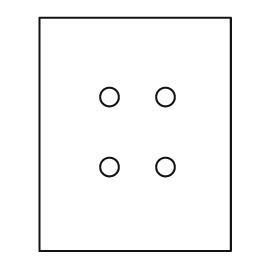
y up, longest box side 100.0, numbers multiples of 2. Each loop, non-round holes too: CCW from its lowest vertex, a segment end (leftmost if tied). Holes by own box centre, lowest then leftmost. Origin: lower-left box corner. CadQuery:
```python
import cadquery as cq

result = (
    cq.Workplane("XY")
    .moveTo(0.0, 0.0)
    .lineTo(82.0, 0.0)
    .lineTo(82.0, 100.0)
    .lineTo(0.0, 100.0)
    .close()
    .moveTo(30.0, 36.0)
    .circle(4.0)
    .moveTo(54.0, 36.0)
    .circle(4.0)
    .moveTo(30.0, 66.0)
    .circle(4.0)
    .moveTo(54.0, 66.0)
    .circle(4.0)
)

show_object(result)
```